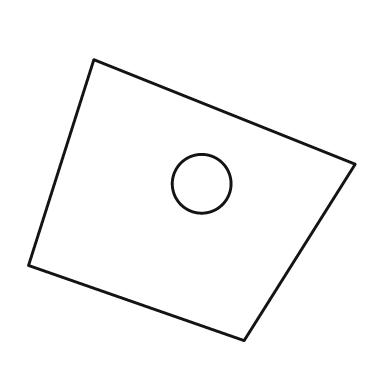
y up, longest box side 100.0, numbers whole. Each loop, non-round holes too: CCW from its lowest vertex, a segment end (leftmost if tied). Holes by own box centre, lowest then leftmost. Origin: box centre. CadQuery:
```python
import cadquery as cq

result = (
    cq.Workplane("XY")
    .moveTo(16.0, -43.0)
    .lineTo(50.0, 11.0)
    .lineTo(-30.0, 43.0)
    .lineTo(-50.0, -20.0)
    .close()
    .moveTo(3.0, 5.0)
    .circle(9.0)
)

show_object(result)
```